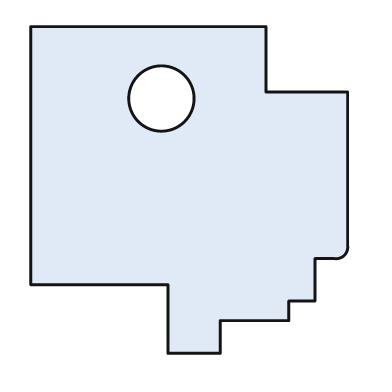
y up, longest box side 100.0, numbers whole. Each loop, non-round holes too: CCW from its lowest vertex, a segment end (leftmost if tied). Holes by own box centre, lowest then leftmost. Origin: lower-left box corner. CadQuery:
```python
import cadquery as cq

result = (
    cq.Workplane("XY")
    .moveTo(42.0, 0.0)
    .lineTo(58.0, 0.0)
    .lineTo(58.0, 10.0)
    .lineTo(79.0, 10.0)
    .lineTo(79.0, 16.0)
    .lineTo(87.0, 16.0)
    .lineTo(87.0, 29.0)
    .lineTo(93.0, 29.0)
    .threePointArc((96.0, 30.0), (97.0, 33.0))
    .lineTo(97.0, 80.0)
    .lineTo(72.0, 80.0)
    .lineTo(72.0, 100.0)
    .lineTo(0.0, 100.0)
    .lineTo(0.0, 21.0)
    .lineTo(42.0, 21.0)
    .close()
    .moveTo(40.0, 78.0)
    .circle(10.0)
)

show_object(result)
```